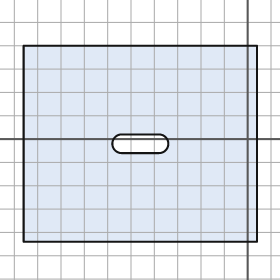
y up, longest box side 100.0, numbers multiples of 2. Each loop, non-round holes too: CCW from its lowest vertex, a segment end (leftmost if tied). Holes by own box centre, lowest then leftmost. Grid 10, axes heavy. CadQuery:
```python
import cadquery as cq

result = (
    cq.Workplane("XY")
    .moveTo(-96.0, -44.0)
    .lineTo(4.0, -44.0)
    .lineTo(4.0, 40.0)
    .lineTo(-96.0, 40.0)
    .close()
    .moveTo(-54.0, -6.0)
    .lineTo(-38.0, -6.0)
    .threePointArc((-34.0, -2.0), (-38.0, 2.0))
    .lineTo(-54.0, 2.0)
    .threePointArc((-58.0, -2.0), (-54.0, -6.0))
    .close()
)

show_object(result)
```